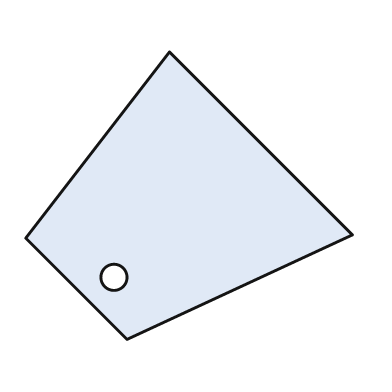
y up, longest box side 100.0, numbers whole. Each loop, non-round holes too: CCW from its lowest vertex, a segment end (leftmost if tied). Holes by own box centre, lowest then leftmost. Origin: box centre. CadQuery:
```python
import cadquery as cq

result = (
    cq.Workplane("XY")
    .moveTo(-19.0, -44.0)
    .lineTo(50.0, -12.0)
    .lineTo(-6.0, 44.0)
    .lineTo(-50.0, -13.0)
    .close()
    .moveTo(-23.0, -25.0)
    .circle(4.0)
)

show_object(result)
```